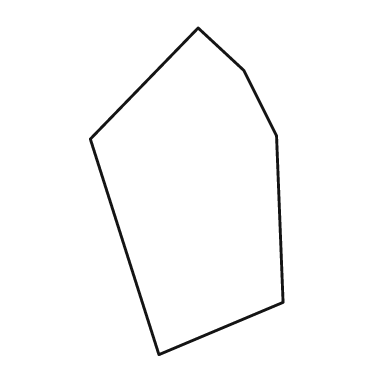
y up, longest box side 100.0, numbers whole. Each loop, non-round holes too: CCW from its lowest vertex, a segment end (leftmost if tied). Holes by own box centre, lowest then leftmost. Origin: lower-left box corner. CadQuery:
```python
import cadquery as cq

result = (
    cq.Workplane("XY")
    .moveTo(21.0, 0.0)
    .lineTo(59.0, 16.0)
    .lineTo(57.0, 67.0)
    .lineTo(47.0, 87.0)
    .lineTo(33.0, 100.0)
    .lineTo(0.0, 66.0)
    .close()
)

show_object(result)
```